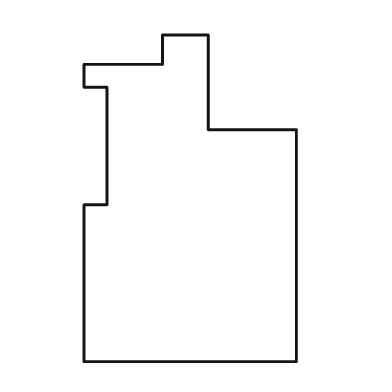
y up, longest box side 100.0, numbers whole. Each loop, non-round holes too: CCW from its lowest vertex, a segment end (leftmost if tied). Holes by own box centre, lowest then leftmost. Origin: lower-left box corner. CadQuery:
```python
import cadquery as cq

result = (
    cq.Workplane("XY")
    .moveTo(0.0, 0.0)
    .lineTo(65.0, 0.0)
    .lineTo(65.0, 71.0)
    .lineTo(38.0, 71.0)
    .lineTo(38.0, 100.0)
    .lineTo(24.0, 100.0)
    .lineTo(24.0, 91.0)
    .lineTo(0.0, 91.0)
    .lineTo(0.0, 84.0)
    .lineTo(7.0, 84.0)
    .lineTo(7.0, 48.0)
    .lineTo(0.0, 48.0)
    .close()
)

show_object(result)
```